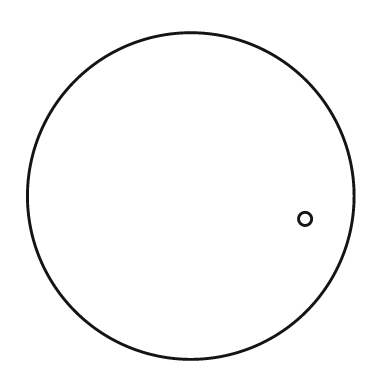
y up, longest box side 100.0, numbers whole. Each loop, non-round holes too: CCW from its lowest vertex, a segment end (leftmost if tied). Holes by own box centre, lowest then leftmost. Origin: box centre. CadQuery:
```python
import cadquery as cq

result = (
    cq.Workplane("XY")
    .moveTo(0.0, 0.0)
    .circle(50.0)
    .moveTo(35.0, -7.0)
    .circle(2.0)
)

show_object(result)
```